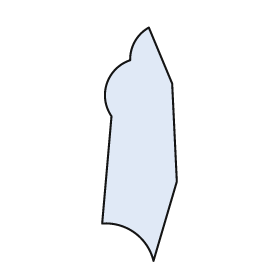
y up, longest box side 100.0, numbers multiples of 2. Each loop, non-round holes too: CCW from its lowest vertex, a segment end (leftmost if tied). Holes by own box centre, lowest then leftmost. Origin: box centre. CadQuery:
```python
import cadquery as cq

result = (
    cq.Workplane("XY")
    .moveTo(6.0, -50.0)
    .lineTo(16.0, -16.0)
    .lineTo(14.0, 26.0)
    .lineTo(4.0, 50.0)
    .threePointArc((-2.0, 44.0), (-4.0, 36.0))
    .threePointArc((-14.0, 26.0), (-12.0, 12.0))
    .lineTo(-16.0, -34.0)
    .threePointArc((-2.0, -38.0), (6.0, -50.0))
    .close()
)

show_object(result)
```